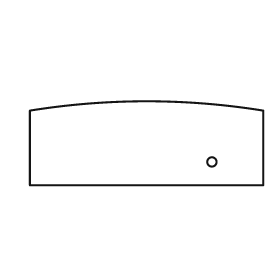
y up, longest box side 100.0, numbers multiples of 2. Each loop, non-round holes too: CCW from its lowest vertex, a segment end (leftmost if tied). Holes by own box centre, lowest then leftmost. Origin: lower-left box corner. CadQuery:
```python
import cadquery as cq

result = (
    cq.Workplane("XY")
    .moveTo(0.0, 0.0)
    .lineTo(100.0, 0.0)
    .lineTo(100.0, 32.0)
    .threePointArc((50.0, 36.0), (0.0, 32.0))
    .close()
    .moveTo(78.0, 10.0)
    .circle(2.0)
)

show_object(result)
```